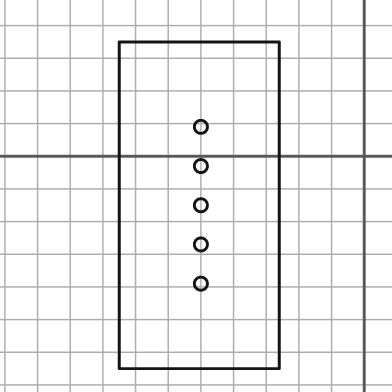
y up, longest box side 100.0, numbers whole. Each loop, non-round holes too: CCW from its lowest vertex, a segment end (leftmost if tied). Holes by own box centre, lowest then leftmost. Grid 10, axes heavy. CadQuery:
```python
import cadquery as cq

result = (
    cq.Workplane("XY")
    .moveTo(-75.0, -65.0)
    .lineTo(-26.0, -65.0)
    .lineTo(-26.0, 35.0)
    .lineTo(-75.0, 35.0)
    .close()
    .moveTo(-50.0, -39.0)
    .circle(2.0)
    .moveTo(-50.0, -27.0)
    .circle(2.0)
    .moveTo(-50.0, -15.0)
    .circle(2.0)
    .moveTo(-50.0, -3.0)
    .circle(2.0)
    .moveTo(-50.0, 9.0)
    .circle(2.0)
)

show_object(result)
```